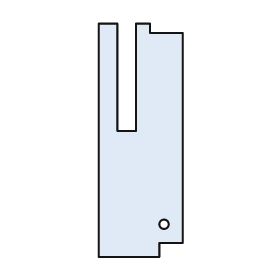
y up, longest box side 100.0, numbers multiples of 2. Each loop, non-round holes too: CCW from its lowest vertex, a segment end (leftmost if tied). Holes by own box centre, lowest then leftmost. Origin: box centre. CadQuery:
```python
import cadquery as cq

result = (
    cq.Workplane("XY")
    .moveTo(-18.0, -50.0)
    .lineTo(8.0, -50.0)
    .lineTo(8.0, -44.0)
    .lineTo(18.0, -44.0)
    .lineTo(18.0, 46.0)
    .lineTo(4.0, 46.0)
    .lineTo(4.0, 50.0)
    .lineTo(-2.0, 50.0)
    .lineTo(-2.0, 4.0)
    .lineTo(-10.0, 4.0)
    .lineTo(-10.0, 50.0)
    .lineTo(-18.0, 50.0)
    .close()
    .moveTo(10.0, -36.0)
    .circle(2.0)
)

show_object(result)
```